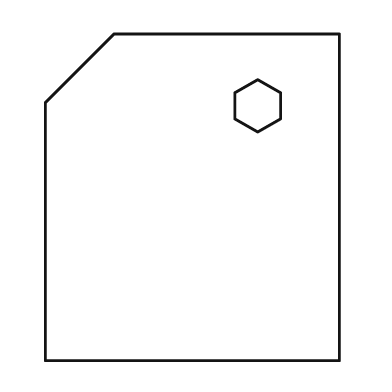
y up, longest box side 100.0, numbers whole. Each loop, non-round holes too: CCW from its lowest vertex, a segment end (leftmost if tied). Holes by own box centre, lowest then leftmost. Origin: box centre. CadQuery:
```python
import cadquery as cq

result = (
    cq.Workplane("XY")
    .moveTo(-45.0, -50.0)
    .lineTo(45.0, -50.0)
    .lineTo(45.0, 50.0)
    .lineTo(-24.0, 50.0)
    .lineTo(-45.0, 29.0)
    .close()
    .moveTo(20.0, 20.0)
    .lineTo(27.0, 24.0)
    .lineTo(27.0, 32.0)
    .lineTo(20.0, 36.0)
    .lineTo(13.0, 32.0)
    .lineTo(13.0, 24.0)
    .close()
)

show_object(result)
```